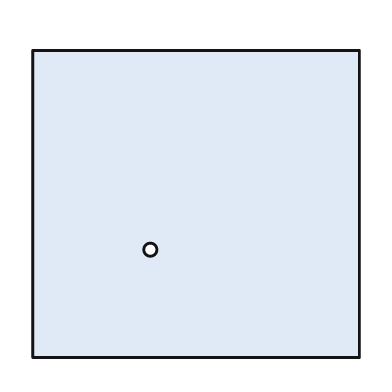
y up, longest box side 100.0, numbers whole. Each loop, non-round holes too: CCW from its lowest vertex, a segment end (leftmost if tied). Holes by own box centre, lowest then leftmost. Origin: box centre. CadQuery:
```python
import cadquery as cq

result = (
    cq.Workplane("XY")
    .moveTo(-50.0, -47.0)
    .lineTo(50.0, -47.0)
    .lineTo(50.0, 47.0)
    .lineTo(-50.0, 47.0)
    .close()
    .moveTo(-14.0, -14.0)
    .circle(2.0)
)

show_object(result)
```